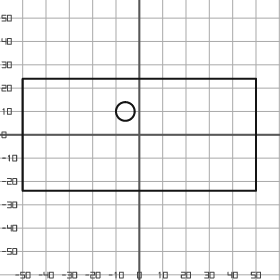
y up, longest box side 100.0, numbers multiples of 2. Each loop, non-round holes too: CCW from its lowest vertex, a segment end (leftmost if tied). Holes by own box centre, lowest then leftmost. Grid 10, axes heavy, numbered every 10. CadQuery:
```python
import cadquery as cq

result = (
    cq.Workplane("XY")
    .moveTo(-50.0, -24.0)
    .lineTo(50.0, -24.0)
    .lineTo(50.0, 24.0)
    .lineTo(-50.0, 24.0)
    .close()
    .moveTo(-6.0, 10.0)
    .circle(4.0)
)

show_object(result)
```